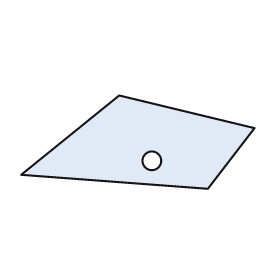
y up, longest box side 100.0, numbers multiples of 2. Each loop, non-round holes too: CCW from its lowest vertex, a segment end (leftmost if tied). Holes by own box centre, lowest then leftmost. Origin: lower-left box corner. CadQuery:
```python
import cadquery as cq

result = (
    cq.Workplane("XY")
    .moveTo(80.0, 0.0)
    .lineTo(100.0, 26.0)
    .lineTo(42.0, 40.0)
    .lineTo(0.0, 6.0)
    .close()
    .moveTo(56.0, 12.0)
    .circle(4.0)
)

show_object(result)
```